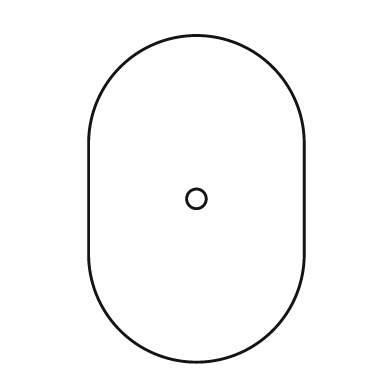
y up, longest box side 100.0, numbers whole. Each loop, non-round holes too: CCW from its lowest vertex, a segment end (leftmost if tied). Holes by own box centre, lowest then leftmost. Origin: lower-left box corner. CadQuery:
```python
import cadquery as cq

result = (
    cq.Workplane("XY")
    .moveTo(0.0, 33.0)
    .threePointArc((33.0, 0.0), (66.0, 33.0))
    .lineTo(66.0, 67.0)
    .threePointArc((33.0, 100.0), (0.0, 67.0))
    .close()
    .moveTo(33.0, 50.0)
    .circle(3.0)
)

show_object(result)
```